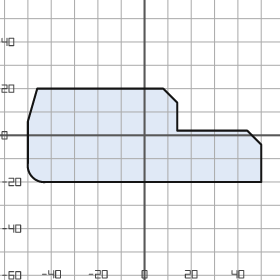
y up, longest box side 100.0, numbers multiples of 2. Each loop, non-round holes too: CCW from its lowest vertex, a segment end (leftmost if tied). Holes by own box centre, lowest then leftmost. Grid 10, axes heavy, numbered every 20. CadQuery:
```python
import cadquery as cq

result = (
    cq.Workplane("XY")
    .moveTo(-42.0, -20.0)
    .lineTo(50.0, -20.0)
    .lineTo(50.0, -4.0)
    .lineTo(44.0, 2.0)
    .lineTo(14.0, 2.0)
    .lineTo(14.0, 14.0)
    .lineTo(8.0, 20.0)
    .lineTo(-46.0, 20.0)
    .lineTo(-50.0, 6.0)
    .lineTo(-50.0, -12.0)
    .threePointArc((-48.0, -18.0), (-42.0, -20.0))
    .close()
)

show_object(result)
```